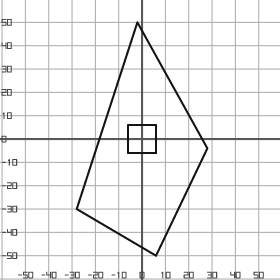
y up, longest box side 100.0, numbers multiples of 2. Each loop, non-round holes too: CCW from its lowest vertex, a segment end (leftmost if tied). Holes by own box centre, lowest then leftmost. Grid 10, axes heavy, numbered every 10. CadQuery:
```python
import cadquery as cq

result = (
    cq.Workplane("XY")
    .moveTo(6.0, -50.0)
    .lineTo(28.0, -4.0)
    .lineTo(-2.0, 50.0)
    .lineTo(-28.0, -30.0)
    .close()
    .moveTo(-6.0, -6.0)
    .lineTo(6.0, -6.0)
    .lineTo(6.0, 6.0)
    .lineTo(-6.0, 6.0)
    .close()
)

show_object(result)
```